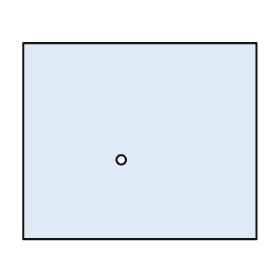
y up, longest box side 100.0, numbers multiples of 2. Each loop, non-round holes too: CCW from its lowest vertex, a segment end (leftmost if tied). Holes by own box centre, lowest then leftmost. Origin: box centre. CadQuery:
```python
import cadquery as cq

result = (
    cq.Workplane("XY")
    .moveTo(-50.0, -42.0)
    .lineTo(50.0, -42.0)
    .lineTo(50.0, 42.0)
    .lineTo(-50.0, 42.0)
    .close()
    .moveTo(-8.0, -8.0)
    .circle(2.0)
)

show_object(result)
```